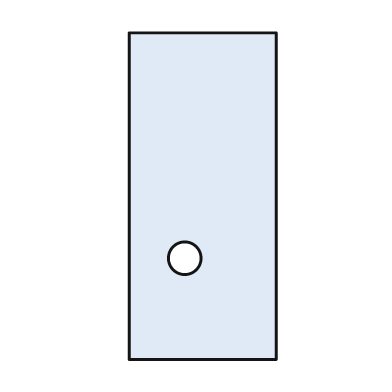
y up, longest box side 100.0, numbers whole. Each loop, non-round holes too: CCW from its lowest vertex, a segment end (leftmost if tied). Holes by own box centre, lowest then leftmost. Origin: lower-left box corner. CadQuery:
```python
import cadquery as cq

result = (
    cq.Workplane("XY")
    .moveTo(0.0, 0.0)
    .lineTo(45.0, 0.0)
    .lineTo(45.0, 100.0)
    .lineTo(0.0, 100.0)
    .close()
    .moveTo(17.0, 31.0)
    .circle(5.0)
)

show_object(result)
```